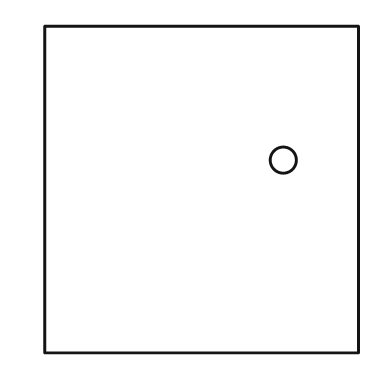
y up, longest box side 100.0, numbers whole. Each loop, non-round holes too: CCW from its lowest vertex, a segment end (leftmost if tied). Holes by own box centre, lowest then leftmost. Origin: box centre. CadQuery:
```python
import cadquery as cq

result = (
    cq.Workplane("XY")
    .moveTo(-48.0, -50.0)
    .lineTo(48.0, -50.0)
    .lineTo(48.0, 50.0)
    .lineTo(-48.0, 50.0)
    .close()
    .moveTo(25.0, 9.0)
    .circle(4.0)
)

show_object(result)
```